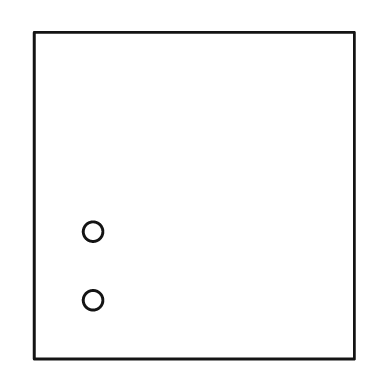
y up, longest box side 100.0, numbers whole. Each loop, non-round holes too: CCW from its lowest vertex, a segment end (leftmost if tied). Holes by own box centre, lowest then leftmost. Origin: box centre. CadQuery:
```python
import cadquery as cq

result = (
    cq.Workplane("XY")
    .moveTo(-49.0, -50.0)
    .lineTo(49.0, -50.0)
    .lineTo(49.0, 50.0)
    .lineTo(-49.0, 50.0)
    .close()
    .moveTo(-31.0, -32.0)
    .circle(3.0)
    .moveTo(-31.0, -11.0)
    .circle(3.0)
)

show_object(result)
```